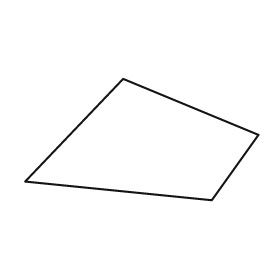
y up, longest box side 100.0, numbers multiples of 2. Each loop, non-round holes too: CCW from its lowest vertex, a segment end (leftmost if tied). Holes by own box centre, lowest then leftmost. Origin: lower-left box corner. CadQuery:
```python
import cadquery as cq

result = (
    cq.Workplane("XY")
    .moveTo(80.0, 0.0)
    .lineTo(100.0, 28.0)
    .lineTo(42.0, 52.0)
    .lineTo(0.0, 8.0)
    .close()
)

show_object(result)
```